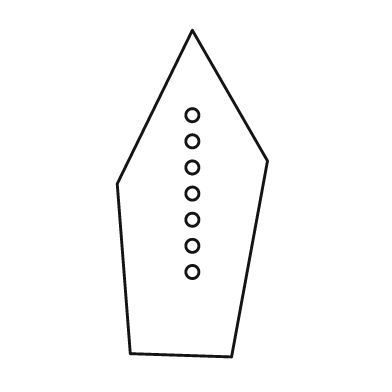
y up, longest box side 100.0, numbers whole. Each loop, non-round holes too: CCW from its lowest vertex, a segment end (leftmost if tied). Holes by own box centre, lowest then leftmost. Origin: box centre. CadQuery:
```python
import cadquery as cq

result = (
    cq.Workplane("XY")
    .moveTo(12.0, -50.0)
    .lineTo(23.0, 10.0)
    .lineTo(0.0, 50.0)
    .lineTo(-23.0, 3.0)
    .lineTo(-19.0, -49.0)
    .close()
    .moveTo(0.0, -24.0)
    .circle(2.0)
    .moveTo(0.0, -16.0)
    .circle(2.0)
    .moveTo(0.0, -8.0)
    .circle(2.0)
    .moveTo(0.0, 0.0)
    .circle(2.0)
    .moveTo(0.0, 8.0)
    .circle(2.0)
    .moveTo(0.0, 16.0)
    .circle(2.0)
    .moveTo(0.0, 24.0)
    .circle(2.0)
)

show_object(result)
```